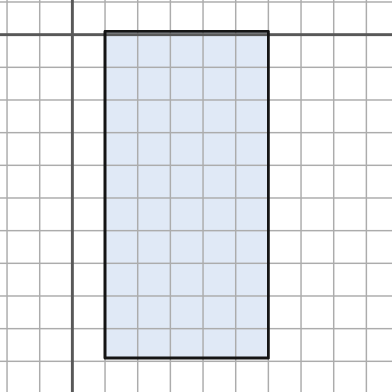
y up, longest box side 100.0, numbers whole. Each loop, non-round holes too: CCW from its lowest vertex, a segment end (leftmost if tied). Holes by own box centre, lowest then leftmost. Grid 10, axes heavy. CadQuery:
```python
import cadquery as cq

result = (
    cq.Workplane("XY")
    .moveTo(10.0, -99.0)
    .lineTo(60.0, -99.0)
    .lineTo(60.0, 1.0)
    .lineTo(10.0, 1.0)
    .close()
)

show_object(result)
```